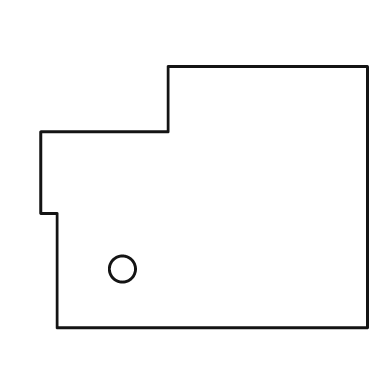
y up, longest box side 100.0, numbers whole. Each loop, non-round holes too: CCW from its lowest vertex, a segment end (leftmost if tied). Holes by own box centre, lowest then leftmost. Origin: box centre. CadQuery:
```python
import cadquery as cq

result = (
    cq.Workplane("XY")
    .moveTo(-45.0, -40.0)
    .lineTo(50.0, -40.0)
    .lineTo(50.0, 40.0)
    .lineTo(-11.0, 40.0)
    .lineTo(-11.0, 20.0)
    .lineTo(-50.0, 20.0)
    .lineTo(-50.0, -5.0)
    .lineTo(-45.0, -5.0)
    .close()
    .moveTo(-25.0, -22.0)
    .circle(4.0)
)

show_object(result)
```